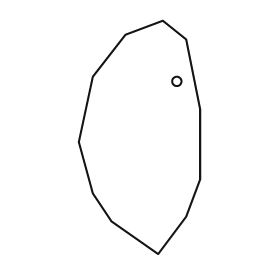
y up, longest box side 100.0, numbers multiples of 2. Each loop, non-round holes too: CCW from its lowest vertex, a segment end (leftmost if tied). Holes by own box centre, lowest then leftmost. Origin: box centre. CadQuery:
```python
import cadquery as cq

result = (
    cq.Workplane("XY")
    .moveTo(8.0, -50.0)
    .lineTo(20.0, -34.0)
    .lineTo(26.0, -18.0)
    .lineTo(26.0, 12.0)
    .lineTo(20.0, 42.0)
    .lineTo(10.0, 50.0)
    .lineTo(-6.0, 44.0)
    .lineTo(-20.0, 26.0)
    .lineTo(-26.0, -2.0)
    .lineTo(-20.0, -24.0)
    .lineTo(-12.0, -36.0)
    .close()
    .moveTo(16.0, 24.0)
    .circle(2.0)
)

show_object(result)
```